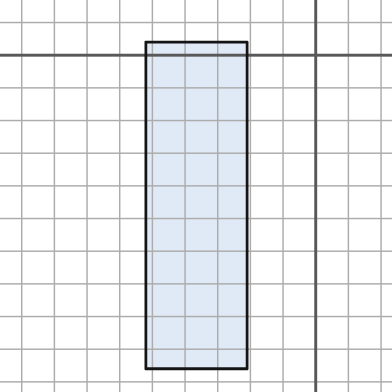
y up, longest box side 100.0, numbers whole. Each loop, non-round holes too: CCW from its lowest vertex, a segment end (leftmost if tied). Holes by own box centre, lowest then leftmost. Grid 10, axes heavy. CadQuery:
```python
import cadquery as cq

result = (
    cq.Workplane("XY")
    .moveTo(-52.0, -96.0)
    .lineTo(-21.0, -96.0)
    .lineTo(-21.0, 4.0)
    .lineTo(-52.0, 4.0)
    .close()
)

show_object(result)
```